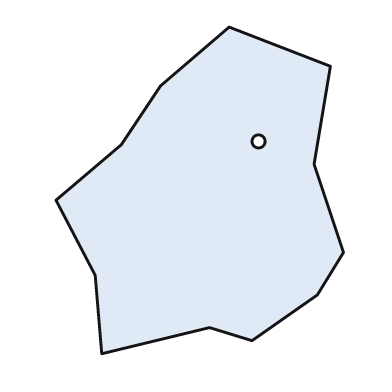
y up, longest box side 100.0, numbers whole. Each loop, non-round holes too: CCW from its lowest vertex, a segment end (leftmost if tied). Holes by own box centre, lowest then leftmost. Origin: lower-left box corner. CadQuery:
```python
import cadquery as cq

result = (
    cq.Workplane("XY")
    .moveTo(14.0, 0.0)
    .lineTo(47.0, 8.0)
    .lineTo(60.0, 4.0)
    .lineTo(80.0, 18.0)
    .lineTo(88.0, 31.0)
    .lineTo(79.0, 58.0)
    .lineTo(84.0, 88.0)
    .lineTo(53.0, 100.0)
    .lineTo(32.0, 82.0)
    .lineTo(20.0, 64.0)
    .lineTo(0.0, 47.0)
    .lineTo(12.0, 24.0)
    .close()
    .moveTo(62.0, 65.0)
    .circle(2.0)
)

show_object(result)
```